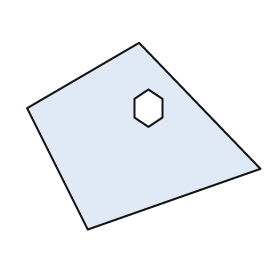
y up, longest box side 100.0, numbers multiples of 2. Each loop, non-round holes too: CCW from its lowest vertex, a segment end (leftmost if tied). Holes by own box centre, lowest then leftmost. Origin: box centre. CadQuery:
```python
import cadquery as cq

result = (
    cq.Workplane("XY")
    .moveTo(-24.0, -40.0)
    .lineTo(50.0, -14.0)
    .lineTo(-2.0, 40.0)
    .lineTo(-50.0, 12.0)
    .close()
    .moveTo(2.0, 4.0)
    .lineTo(8.0, 8.0)
    .lineTo(8.0, 16.0)
    .lineTo(2.0, 20.0)
    .lineTo(-4.0, 16.0)
    .lineTo(-4.0, 8.0)
    .close()
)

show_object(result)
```